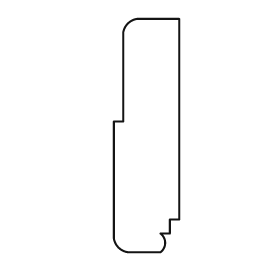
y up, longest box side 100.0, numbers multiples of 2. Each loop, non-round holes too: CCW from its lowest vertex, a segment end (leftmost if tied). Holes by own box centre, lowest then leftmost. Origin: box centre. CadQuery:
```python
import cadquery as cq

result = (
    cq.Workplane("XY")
    .moveTo(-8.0, -50.0)
    .lineTo(6.0, -50.0)
    .threePointArc((8.0, -46.0), (6.0, -42.0))
    .lineTo(10.0, -42.0)
    .lineTo(10.0, -36.0)
    .lineTo(14.0, -36.0)
    .lineTo(14.0, 50.0)
    .lineTo(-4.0, 50.0)
    .threePointArc((-8.0, 48.0), (-10.0, 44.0))
    .lineTo(-10.0, 6.0)
    .lineTo(-14.0, 6.0)
    .lineTo(-14.0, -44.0)
    .threePointArc((-12.0, -48.0), (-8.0, -50.0))
    .close()
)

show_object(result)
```